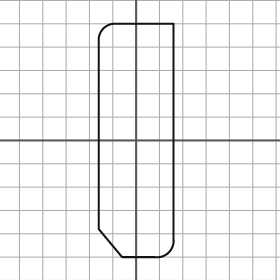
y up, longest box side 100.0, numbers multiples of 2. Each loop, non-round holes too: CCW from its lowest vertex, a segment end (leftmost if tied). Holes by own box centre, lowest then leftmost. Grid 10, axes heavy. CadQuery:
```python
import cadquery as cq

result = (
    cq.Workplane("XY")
    .moveTo(-6.0, -50.0)
    .lineTo(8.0, -50.0)
    .threePointArc((14.0, -48.0), (16.0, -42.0))
    .lineTo(16.0, 50.0)
    .lineTo(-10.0, 50.0)
    .threePointArc((-14.0, 48.0), (-16.0, 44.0))
    .lineTo(-16.0, -38.0)
    .close()
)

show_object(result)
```